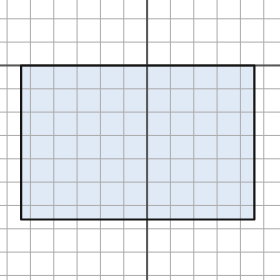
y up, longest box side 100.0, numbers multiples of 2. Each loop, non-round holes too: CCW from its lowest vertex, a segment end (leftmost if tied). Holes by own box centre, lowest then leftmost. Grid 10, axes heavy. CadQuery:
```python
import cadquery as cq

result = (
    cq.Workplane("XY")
    .moveTo(-54.0, -66.0)
    .lineTo(46.0, -66.0)
    .lineTo(46.0, 0.0)
    .lineTo(-54.0, 0.0)
    .close()
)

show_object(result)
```